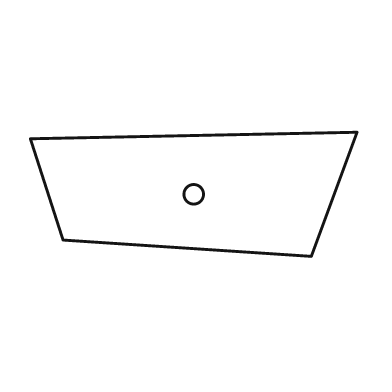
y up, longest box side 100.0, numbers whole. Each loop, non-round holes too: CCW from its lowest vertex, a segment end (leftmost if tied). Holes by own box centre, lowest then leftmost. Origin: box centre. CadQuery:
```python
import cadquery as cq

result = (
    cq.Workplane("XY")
    .moveTo(36.0, -19.0)
    .lineTo(50.0, 19.0)
    .lineTo(-50.0, 17.0)
    .lineTo(-40.0, -14.0)
    .close()
    .moveTo(0.0, 0.0)
    .circle(3.0)
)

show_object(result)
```